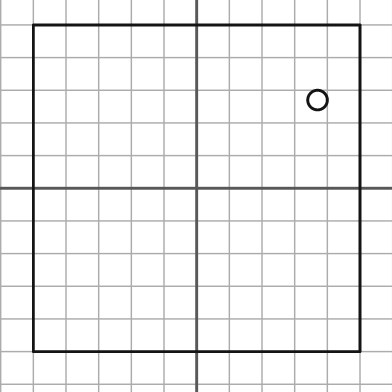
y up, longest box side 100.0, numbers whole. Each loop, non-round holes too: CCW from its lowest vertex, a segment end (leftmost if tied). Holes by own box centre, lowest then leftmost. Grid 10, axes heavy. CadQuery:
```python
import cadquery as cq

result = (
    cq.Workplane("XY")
    .moveTo(-50.0, -50.0)
    .lineTo(50.0, -50.0)
    .lineTo(50.0, 50.0)
    .lineTo(-50.0, 50.0)
    .close()
    .moveTo(37.0, 27.0)
    .circle(3.0)
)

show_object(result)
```